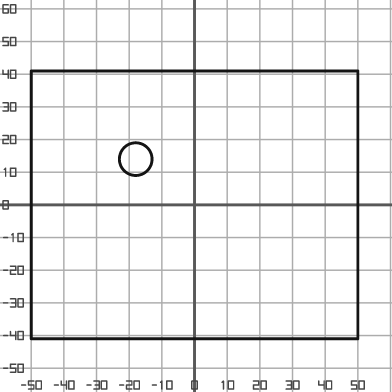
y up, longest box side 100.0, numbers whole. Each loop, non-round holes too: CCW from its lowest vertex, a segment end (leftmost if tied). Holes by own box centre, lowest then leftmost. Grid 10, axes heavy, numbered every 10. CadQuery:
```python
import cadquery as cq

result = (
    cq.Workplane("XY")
    .moveTo(-50.0, -41.0)
    .lineTo(50.0, -41.0)
    .lineTo(50.0, 41.0)
    .lineTo(-50.0, 41.0)
    .close()
    .moveTo(-18.0, 14.0)
    .circle(5.0)
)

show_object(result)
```